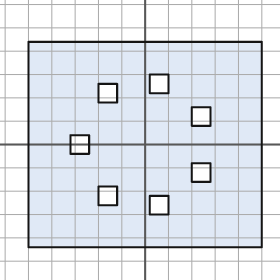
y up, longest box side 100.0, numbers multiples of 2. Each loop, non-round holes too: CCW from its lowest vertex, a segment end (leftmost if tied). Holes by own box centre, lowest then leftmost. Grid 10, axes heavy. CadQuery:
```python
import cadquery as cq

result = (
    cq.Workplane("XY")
    .moveTo(-50.0, -44.0)
    .lineTo(50.0, -44.0)
    .lineTo(50.0, 44.0)
    .lineTo(-50.0, 44.0)
    .close()
    .moveTo(2.0, -30.0)
    .lineTo(10.0, -30.0)
    .lineTo(10.0, -22.0)
    .lineTo(2.0, -22.0)
    .close()
    .moveTo(-20.0, -26.0)
    .lineTo(-12.0, -26.0)
    .lineTo(-12.0, -18.0)
    .lineTo(-20.0, -18.0)
    .close()
    .moveTo(20.0, -16.0)
    .lineTo(28.0, -16.0)
    .lineTo(28.0, -8.0)
    .lineTo(20.0, -8.0)
    .close()
    .moveTo(-32.0, -4.0)
    .lineTo(-24.0, -4.0)
    .lineTo(-24.0, 4.0)
    .lineTo(-32.0, 4.0)
    .close()
    .moveTo(20.0, 8.0)
    .lineTo(28.0, 8.0)
    .lineTo(28.0, 16.0)
    .lineTo(20.0, 16.0)
    .close()
    .moveTo(-20.0, 18.0)
    .lineTo(-12.0, 18.0)
    .lineTo(-12.0, 26.0)
    .lineTo(-20.0, 26.0)
    .close()
    .moveTo(2.0, 22.0)
    .lineTo(10.0, 22.0)
    .lineTo(10.0, 30.0)
    .lineTo(2.0, 30.0)
    .close()
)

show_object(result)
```